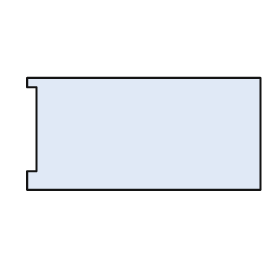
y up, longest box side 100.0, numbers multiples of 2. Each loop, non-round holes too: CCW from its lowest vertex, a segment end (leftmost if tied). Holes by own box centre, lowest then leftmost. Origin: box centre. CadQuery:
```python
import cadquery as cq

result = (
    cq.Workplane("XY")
    .moveTo(-50.0, -24.0)
    .lineTo(50.0, -24.0)
    .lineTo(50.0, 24.0)
    .lineTo(-50.0, 24.0)
    .lineTo(-50.0, 20.0)
    .lineTo(-46.0, 20.0)
    .lineTo(-46.0, -16.0)
    .lineTo(-50.0, -16.0)
    .close()
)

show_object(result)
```